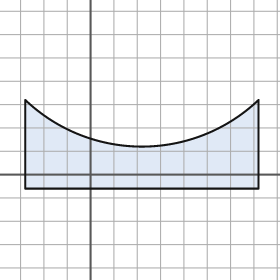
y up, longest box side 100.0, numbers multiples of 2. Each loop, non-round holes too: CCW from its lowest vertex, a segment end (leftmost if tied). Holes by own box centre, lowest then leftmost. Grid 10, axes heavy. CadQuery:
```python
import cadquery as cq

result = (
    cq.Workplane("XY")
    .moveTo(-28.0, -6.0)
    .lineTo(72.0, -6.0)
    .lineTo(72.0, 32.0)
    .threePointArc((22.0, 12.0), (-28.0, 32.0))
    .close()
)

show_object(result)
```